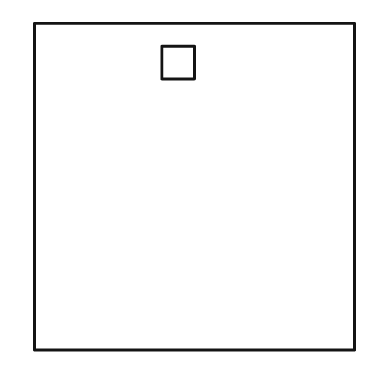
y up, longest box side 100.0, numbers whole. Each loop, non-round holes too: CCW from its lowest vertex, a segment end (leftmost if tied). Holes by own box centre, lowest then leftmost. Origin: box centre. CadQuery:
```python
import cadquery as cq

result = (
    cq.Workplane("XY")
    .moveTo(-49.0, -50.0)
    .lineTo(49.0, -50.0)
    .lineTo(49.0, 50.0)
    .lineTo(-49.0, 50.0)
    .close()
    .moveTo(-10.0, 33.0)
    .lineTo(0.0, 33.0)
    .lineTo(0.0, 43.0)
    .lineTo(-10.0, 43.0)
    .close()
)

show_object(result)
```